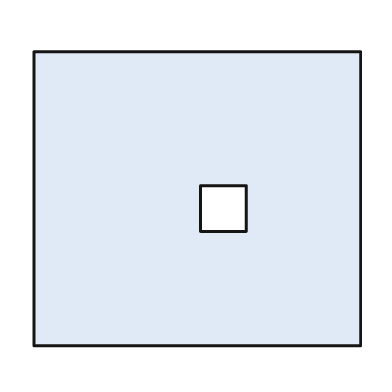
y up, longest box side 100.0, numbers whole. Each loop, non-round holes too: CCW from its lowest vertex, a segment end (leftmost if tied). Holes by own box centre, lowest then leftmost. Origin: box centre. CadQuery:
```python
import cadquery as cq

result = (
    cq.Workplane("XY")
    .moveTo(-50.0, -45.0)
    .lineTo(50.0, -45.0)
    .lineTo(50.0, 45.0)
    .lineTo(-50.0, 45.0)
    .close()
    .moveTo(1.0, -10.0)
    .lineTo(15.0, -10.0)
    .lineTo(15.0, 4.0)
    .lineTo(1.0, 4.0)
    .close()
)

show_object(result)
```